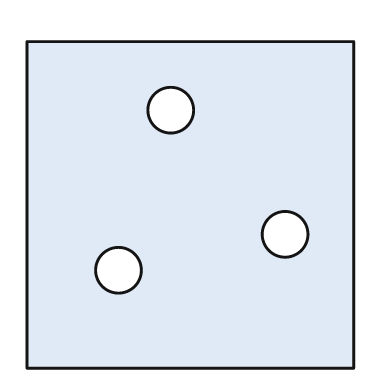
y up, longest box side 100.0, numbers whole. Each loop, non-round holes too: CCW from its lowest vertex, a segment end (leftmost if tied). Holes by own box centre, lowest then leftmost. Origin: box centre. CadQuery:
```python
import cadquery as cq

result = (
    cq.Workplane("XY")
    .moveTo(-50.0, -50.0)
    .lineTo(50.0, -50.0)
    .lineTo(50.0, 50.0)
    .lineTo(-50.0, 50.0)
    .close()
    .moveTo(-22.0, -20.0)
    .circle(7.0)
    .moveTo(29.0, -9.0)
    .circle(7.0)
    .moveTo(-6.0, 29.0)
    .circle(7.0)
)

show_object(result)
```